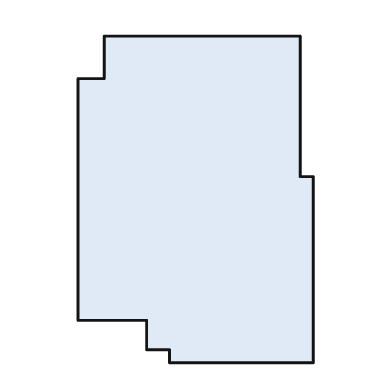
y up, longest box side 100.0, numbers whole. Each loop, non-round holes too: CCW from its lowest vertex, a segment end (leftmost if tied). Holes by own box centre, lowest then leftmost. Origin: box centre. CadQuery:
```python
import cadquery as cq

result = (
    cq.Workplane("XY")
    .moveTo(-8.0, -50.0)
    .lineTo(36.0, -50.0)
    .lineTo(36.0, 7.0)
    .lineTo(32.0, 7.0)
    .lineTo(32.0, 50.0)
    .lineTo(-28.0, 50.0)
    .lineTo(-28.0, 37.0)
    .lineTo(-36.0, 37.0)
    .lineTo(-36.0, -37.0)
    .lineTo(-15.0, -37.0)
    .lineTo(-15.0, -46.0)
    .lineTo(-8.0, -46.0)
    .close()
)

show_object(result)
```